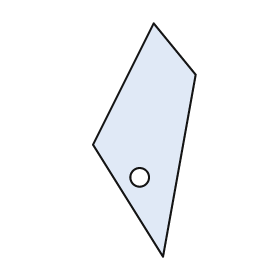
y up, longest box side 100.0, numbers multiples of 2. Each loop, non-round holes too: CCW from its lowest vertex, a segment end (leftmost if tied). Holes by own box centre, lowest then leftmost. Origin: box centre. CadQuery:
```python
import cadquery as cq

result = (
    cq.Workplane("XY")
    .moveTo(8.0, -50.0)
    .lineTo(22.0, 28.0)
    .lineTo(4.0, 50.0)
    .lineTo(-22.0, -2.0)
    .close()
    .moveTo(-2.0, -16.0)
    .circle(4.0)
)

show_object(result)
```